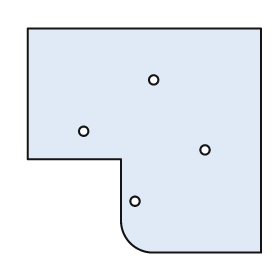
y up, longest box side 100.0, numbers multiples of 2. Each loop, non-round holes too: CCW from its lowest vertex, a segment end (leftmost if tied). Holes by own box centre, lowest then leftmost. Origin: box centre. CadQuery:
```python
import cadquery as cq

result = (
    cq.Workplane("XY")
    .moveTo(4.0, -48.0)
    .lineTo(50.0, -48.0)
    .lineTo(50.0, 48.0)
    .lineTo(-50.0, 48.0)
    .lineTo(-50.0, -8.0)
    .lineTo(-10.0, -8.0)
    .lineTo(-10.0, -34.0)
    .threePointArc((-6.0, -44.0), (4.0, -48.0))
    .close()
    .moveTo(-4.0, -26.0)
    .circle(2.0)
    .moveTo(26.0, -4.0)
    .circle(2.0)
    .moveTo(-26.0, 4.0)
    .circle(2.0)
    .moveTo(4.0, 26.0)
    .circle(2.0)
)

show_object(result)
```